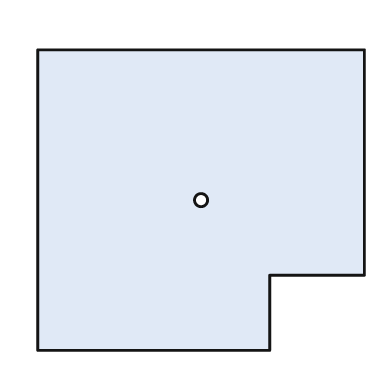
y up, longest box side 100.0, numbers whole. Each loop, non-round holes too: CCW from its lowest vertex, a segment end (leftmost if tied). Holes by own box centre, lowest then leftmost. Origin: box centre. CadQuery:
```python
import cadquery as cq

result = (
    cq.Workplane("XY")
    .moveTo(-50.0, -46.0)
    .lineTo(21.0, -46.0)
    .lineTo(21.0, -23.0)
    .lineTo(50.0, -23.0)
    .lineTo(50.0, 46.0)
    .lineTo(-50.0, 46.0)
    .close()
    .moveTo(0.0, 0.0)
    .circle(2.0)
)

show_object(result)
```